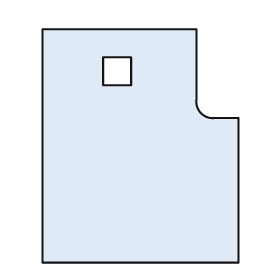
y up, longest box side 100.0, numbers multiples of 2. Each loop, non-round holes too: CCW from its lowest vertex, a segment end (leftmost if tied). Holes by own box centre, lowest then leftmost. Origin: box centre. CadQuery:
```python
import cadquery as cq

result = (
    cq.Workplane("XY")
    .moveTo(-42.0, -50.0)
    .lineTo(42.0, -50.0)
    .lineTo(42.0, 12.0)
    .lineTo(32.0, 12.0)
    .threePointArc((26.0, 14.0), (24.0, 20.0))
    .lineTo(24.0, 50.0)
    .lineTo(-42.0, 50.0)
    .close()
    .moveTo(-16.0, 26.0)
    .lineTo(-4.0, 26.0)
    .lineTo(-4.0, 38.0)
    .lineTo(-16.0, 38.0)
    .close()
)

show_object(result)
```